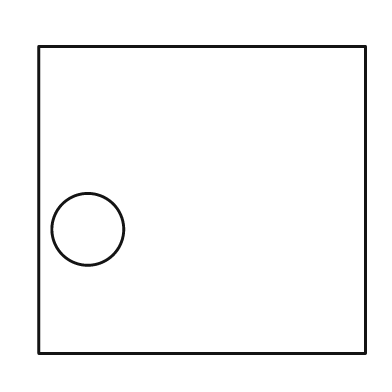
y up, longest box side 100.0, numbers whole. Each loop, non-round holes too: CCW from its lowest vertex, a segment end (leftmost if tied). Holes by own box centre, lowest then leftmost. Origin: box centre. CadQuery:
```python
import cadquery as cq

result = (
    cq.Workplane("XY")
    .moveTo(-50.0, -47.0)
    .lineTo(50.0, -47.0)
    .lineTo(50.0, 47.0)
    .lineTo(-50.0, 47.0)
    .close()
    .moveTo(-35.0, -9.0)
    .circle(11.0)
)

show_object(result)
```